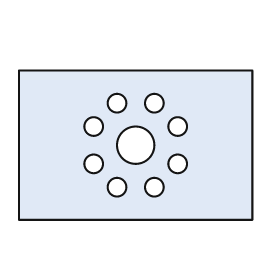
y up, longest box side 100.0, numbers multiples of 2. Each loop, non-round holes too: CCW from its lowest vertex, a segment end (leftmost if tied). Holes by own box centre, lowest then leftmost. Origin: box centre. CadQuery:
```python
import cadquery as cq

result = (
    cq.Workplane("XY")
    .moveTo(-50.0, -32.0)
    .lineTo(50.0, -32.0)
    .lineTo(50.0, 32.0)
    .lineTo(-50.0, 32.0)
    .close()
    .moveTo(-8.0, -18.0)
    .circle(4.0)
    .moveTo(8.0, -18.0)
    .circle(4.0)
    .moveTo(-18.0, -8.0)
    .circle(4.0)
    .moveTo(18.0, -8.0)
    .circle(4.0)
    .moveTo(0.0, 0.0)
    .circle(8.0)
    .moveTo(-18.0, 8.0)
    .circle(4.0)
    .moveTo(18.0, 8.0)
    .circle(4.0)
    .moveTo(-8.0, 18.0)
    .circle(4.0)
    .moveTo(8.0, 18.0)
    .circle(4.0)
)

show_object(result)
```